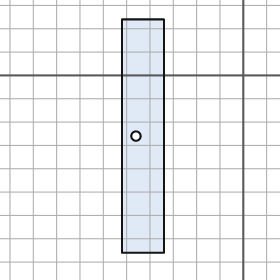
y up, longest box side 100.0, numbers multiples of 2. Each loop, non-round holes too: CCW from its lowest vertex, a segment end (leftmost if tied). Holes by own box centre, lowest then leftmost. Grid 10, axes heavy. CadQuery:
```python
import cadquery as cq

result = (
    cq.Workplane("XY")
    .moveTo(-52.0, -76.0)
    .lineTo(-34.0, -76.0)
    .lineTo(-34.0, 24.0)
    .lineTo(-52.0, 24.0)
    .close()
    .moveTo(-46.0, -26.0)
    .circle(2.0)
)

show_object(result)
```